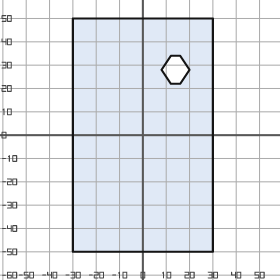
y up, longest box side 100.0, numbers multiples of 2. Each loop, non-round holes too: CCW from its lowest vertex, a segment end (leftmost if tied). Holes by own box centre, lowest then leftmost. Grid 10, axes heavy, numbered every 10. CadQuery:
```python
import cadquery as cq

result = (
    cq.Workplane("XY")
    .moveTo(-30.0, -50.0)
    .lineTo(30.0, -50.0)
    .lineTo(30.0, 50.0)
    .lineTo(-30.0, 50.0)
    .close()
    .moveTo(12.0, 22.0)
    .lineTo(16.0, 22.0)
    .lineTo(20.0, 28.0)
    .lineTo(16.0, 34.0)
    .lineTo(12.0, 34.0)
    .lineTo(8.0, 28.0)
    .close()
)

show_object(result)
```